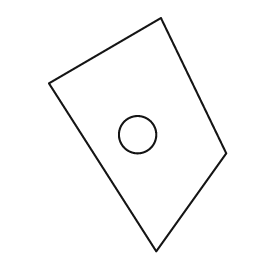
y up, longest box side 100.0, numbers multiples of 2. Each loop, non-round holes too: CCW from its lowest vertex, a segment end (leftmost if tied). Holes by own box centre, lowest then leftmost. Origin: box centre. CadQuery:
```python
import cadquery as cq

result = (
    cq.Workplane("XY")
    .moveTo(8.0, -50.0)
    .lineTo(38.0, -8.0)
    .lineTo(10.0, 50.0)
    .lineTo(-38.0, 22.0)
    .close()
    .moveTo(0.0, 0.0)
    .circle(8.0)
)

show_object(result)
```